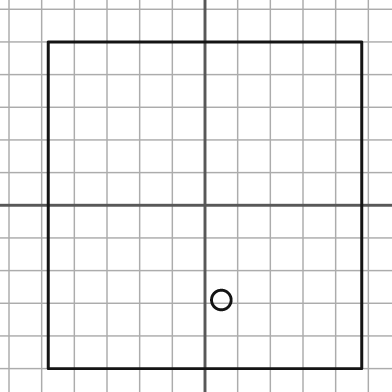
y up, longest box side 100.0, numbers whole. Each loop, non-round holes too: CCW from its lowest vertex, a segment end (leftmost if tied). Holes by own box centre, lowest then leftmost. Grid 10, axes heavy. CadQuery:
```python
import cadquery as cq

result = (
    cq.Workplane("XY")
    .moveTo(-48.0, -50.0)
    .lineTo(48.0, -50.0)
    .lineTo(48.0, 50.0)
    .lineTo(-48.0, 50.0)
    .close()
    .moveTo(5.0, -29.0)
    .circle(3.0)
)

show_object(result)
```